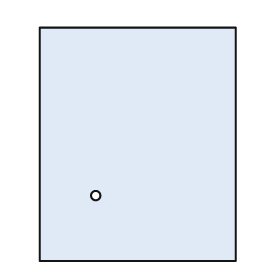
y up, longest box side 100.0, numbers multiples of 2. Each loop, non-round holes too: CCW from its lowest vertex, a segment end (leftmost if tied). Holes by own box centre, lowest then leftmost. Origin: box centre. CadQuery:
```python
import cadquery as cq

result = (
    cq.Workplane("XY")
    .moveTo(-42.0, -50.0)
    .lineTo(42.0, -50.0)
    .lineTo(42.0, 50.0)
    .lineTo(-42.0, 50.0)
    .close()
    .moveTo(-18.0, -22.0)
    .circle(2.0)
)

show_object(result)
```